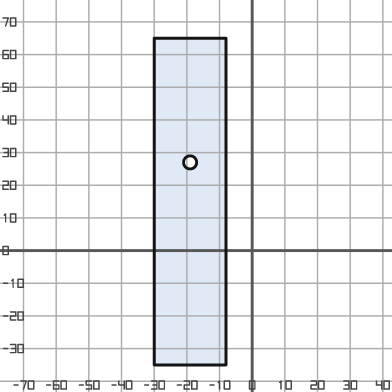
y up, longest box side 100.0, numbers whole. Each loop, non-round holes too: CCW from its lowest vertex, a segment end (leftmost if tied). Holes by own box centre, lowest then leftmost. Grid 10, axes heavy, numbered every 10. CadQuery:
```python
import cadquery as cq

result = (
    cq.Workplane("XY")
    .moveTo(-30.0, -35.0)
    .lineTo(-8.0, -35.0)
    .lineTo(-8.0, 65.0)
    .lineTo(-30.0, 65.0)
    .close()
    .moveTo(-19.0, 27.0)
    .circle(2.0)
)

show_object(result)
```